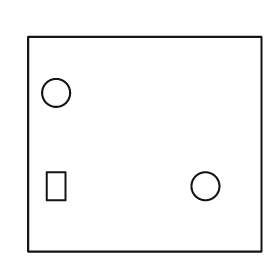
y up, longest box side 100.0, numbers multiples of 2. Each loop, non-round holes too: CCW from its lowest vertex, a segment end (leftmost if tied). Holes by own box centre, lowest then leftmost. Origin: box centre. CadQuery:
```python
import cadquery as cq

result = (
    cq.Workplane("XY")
    .moveTo(-50.0, -46.0)
    .lineTo(50.0, -46.0)
    .lineTo(50.0, 46.0)
    .lineTo(-50.0, 46.0)
    .close()
    .moveTo(-42.0, -24.0)
    .lineTo(-34.0, -24.0)
    .lineTo(-34.0, -12.0)
    .lineTo(-42.0, -12.0)
    .close()
    .moveTo(26.0, -18.0)
    .circle(6.0)
    .moveTo(-38.0, 22.0)
    .circle(6.0)
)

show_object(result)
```